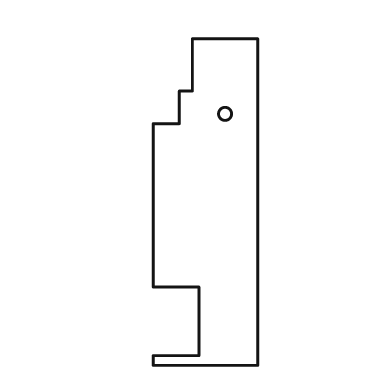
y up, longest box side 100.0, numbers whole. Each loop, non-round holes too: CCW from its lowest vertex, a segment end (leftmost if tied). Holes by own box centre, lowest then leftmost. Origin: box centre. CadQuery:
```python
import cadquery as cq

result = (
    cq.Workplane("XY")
    .moveTo(-16.0, -50.0)
    .lineTo(16.0, -50.0)
    .lineTo(16.0, 50.0)
    .lineTo(-4.0, 50.0)
    .lineTo(-4.0, 34.0)
    .lineTo(-8.0, 34.0)
    .lineTo(-8.0, 24.0)
    .lineTo(-16.0, 24.0)
    .lineTo(-16.0, -26.0)
    .lineTo(-2.0, -26.0)
    .lineTo(-2.0, -47.0)
    .lineTo(-16.0, -47.0)
    .close()
    .moveTo(6.0, 27.0)
    .circle(2.0)
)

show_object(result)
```